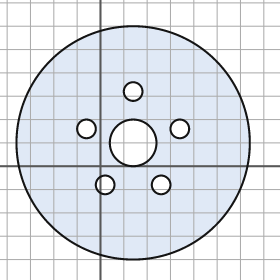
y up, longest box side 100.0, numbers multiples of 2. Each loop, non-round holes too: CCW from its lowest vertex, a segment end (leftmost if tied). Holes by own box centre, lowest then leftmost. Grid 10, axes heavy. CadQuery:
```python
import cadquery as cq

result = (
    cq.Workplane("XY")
    .moveTo(14.0, 10.0)
    .circle(50.0)
    .moveTo(2.0, -8.0)
    .circle(4.0)
    .moveTo(26.0, -8.0)
    .circle(4.0)
    .moveTo(14.0, 10.0)
    .circle(10.0)
    .moveTo(-6.0, 16.0)
    .circle(4.0)
    .moveTo(34.0, 16.0)
    .circle(4.0)
    .moveTo(14.0, 32.0)
    .circle(4.0)
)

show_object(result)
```